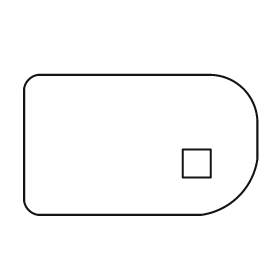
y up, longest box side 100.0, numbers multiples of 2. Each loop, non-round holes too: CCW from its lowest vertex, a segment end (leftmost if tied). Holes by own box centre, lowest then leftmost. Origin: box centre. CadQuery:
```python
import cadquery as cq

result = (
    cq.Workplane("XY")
    .moveTo(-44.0, -30.0)
    .lineTo(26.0, -30.0)
    .threePointArc((42.0, -22.0), (50.0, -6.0))
    .lineTo(50.0, 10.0)
    .threePointArc((44.0, 24.0), (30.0, 30.0))
    .lineTo(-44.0, 30.0)
    .threePointArc((-48.0, 28.0), (-50.0, 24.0))
    .lineTo(-50.0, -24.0)
    .threePointArc((-48.0, -28.0), (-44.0, -30.0))
    .close()
    .moveTo(18.0, -14.0)
    .lineTo(30.0, -14.0)
    .lineTo(30.0, -2.0)
    .lineTo(18.0, -2.0)
    .close()
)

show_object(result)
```